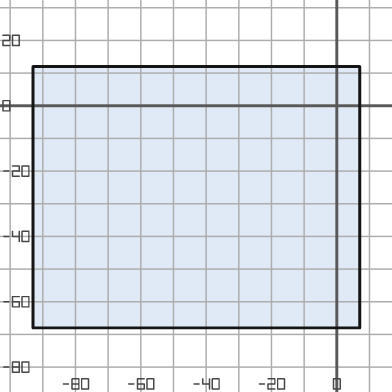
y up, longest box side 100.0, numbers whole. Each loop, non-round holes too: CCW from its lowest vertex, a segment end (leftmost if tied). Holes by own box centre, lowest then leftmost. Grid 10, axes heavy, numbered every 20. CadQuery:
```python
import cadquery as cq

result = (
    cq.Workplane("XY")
    .moveTo(-93.0, -68.0)
    .lineTo(7.0, -68.0)
    .lineTo(7.0, 12.0)
    .lineTo(-93.0, 12.0)
    .close()
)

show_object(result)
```